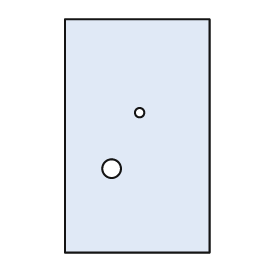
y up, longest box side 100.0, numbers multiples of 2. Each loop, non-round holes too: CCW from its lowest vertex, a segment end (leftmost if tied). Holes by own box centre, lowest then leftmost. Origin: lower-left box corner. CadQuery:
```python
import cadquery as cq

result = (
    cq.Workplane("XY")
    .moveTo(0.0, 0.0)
    .lineTo(62.0, 0.0)
    .lineTo(62.0, 100.0)
    .lineTo(0.0, 100.0)
    .close()
    .moveTo(20.0, 36.0)
    .circle(4.0)
    .moveTo(32.0, 60.0)
    .circle(2.0)
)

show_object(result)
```